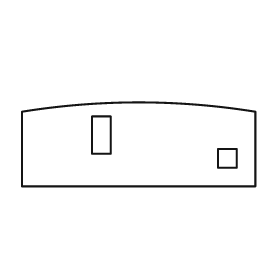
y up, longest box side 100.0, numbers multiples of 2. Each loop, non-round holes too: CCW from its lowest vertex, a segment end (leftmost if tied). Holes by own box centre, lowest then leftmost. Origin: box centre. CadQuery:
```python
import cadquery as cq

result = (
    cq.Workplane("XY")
    .moveTo(-50.0, -18.0)
    .lineTo(50.0, -18.0)
    .lineTo(50.0, 14.0)
    .threePointArc((0.0, 18.0), (-50.0, 14.0))
    .close()
    .moveTo(34.0, -10.0)
    .lineTo(42.0, -10.0)
    .lineTo(42.0, -2.0)
    .lineTo(34.0, -2.0)
    .close()
    .moveTo(-20.0, -4.0)
    .lineTo(-12.0, -4.0)
    .lineTo(-12.0, 12.0)
    .lineTo(-20.0, 12.0)
    .close()
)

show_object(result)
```